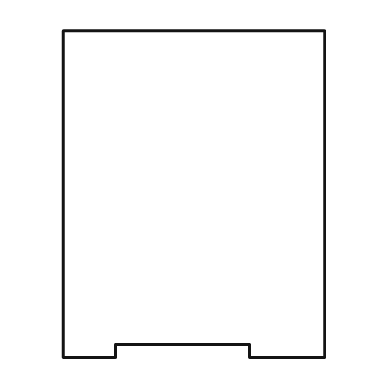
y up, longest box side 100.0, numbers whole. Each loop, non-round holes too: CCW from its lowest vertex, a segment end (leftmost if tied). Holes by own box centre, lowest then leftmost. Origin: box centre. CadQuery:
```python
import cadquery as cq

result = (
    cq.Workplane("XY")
    .moveTo(-40.0, -50.0)
    .lineTo(-24.0, -50.0)
    .lineTo(-24.0, -46.0)
    .lineTo(17.0, -46.0)
    .lineTo(17.0, -50.0)
    .lineTo(40.0, -50.0)
    .lineTo(40.0, 50.0)
    .lineTo(-40.0, 50.0)
    .close()
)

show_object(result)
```